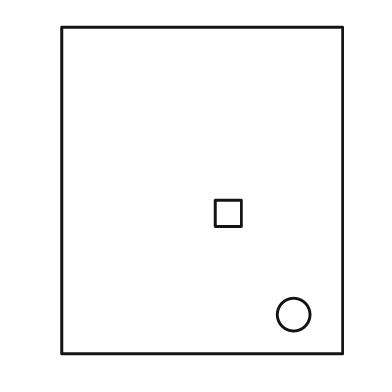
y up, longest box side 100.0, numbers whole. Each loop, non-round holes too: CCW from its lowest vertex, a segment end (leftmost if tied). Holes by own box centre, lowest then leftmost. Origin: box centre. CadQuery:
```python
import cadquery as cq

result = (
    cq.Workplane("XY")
    .moveTo(-43.0, -50.0)
    .lineTo(43.0, -50.0)
    .lineTo(43.0, 50.0)
    .lineTo(-43.0, 50.0)
    .close()
    .moveTo(28.0, -38.0)
    .circle(5.0)
    .moveTo(4.0, -11.0)
    .lineTo(12.0, -11.0)
    .lineTo(12.0, -3.0)
    .lineTo(4.0, -3.0)
    .close()
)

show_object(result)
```